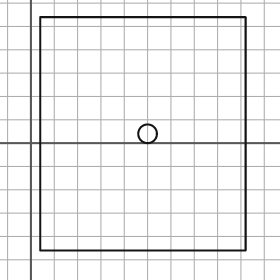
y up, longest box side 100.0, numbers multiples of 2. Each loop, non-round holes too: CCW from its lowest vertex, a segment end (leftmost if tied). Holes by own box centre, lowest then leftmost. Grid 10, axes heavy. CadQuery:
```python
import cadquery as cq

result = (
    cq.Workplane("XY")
    .moveTo(4.0, -46.0)
    .lineTo(92.0, -46.0)
    .lineTo(92.0, 54.0)
    .lineTo(4.0, 54.0)
    .close()
    .moveTo(50.0, 4.0)
    .circle(4.0)
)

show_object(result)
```